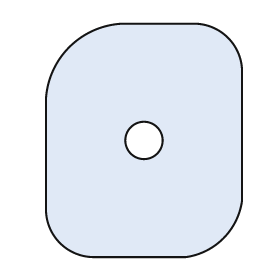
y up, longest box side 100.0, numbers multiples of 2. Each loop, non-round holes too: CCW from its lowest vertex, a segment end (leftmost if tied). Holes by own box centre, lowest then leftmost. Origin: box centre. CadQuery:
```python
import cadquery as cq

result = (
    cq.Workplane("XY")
    .moveTo(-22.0, -50.0)
    .lineTo(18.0, -50.0)
    .threePointArc((34.0, -42.0), (42.0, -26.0))
    .lineTo(42.0, 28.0)
    .threePointArc((36.0, 44.0), (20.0, 50.0))
    .lineTo(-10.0, 50.0)
    .threePointArc((-32.0, 40.0), (-42.0, 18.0))
    .lineTo(-42.0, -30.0)
    .threePointArc((-36.0, -44.0), (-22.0, -50.0))
    .close()
    .moveTo(0.0, 0.0)
    .circle(8.0)
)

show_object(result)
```